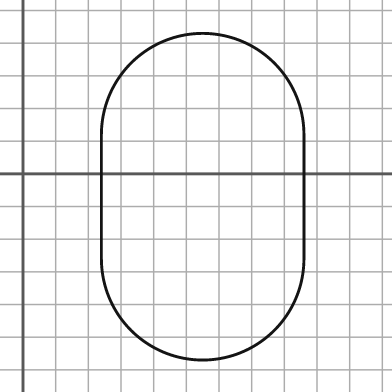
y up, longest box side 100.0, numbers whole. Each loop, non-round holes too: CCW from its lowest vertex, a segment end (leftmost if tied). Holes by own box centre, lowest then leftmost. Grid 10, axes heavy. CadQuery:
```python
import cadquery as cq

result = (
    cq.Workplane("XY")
    .moveTo(24.0, -26.0)
    .threePointArc((55.0, -57.0), (86.0, -26.0))
    .lineTo(86.0, 12.0)
    .threePointArc((55.0, 43.0), (24.0, 12.0))
    .close()
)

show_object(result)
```